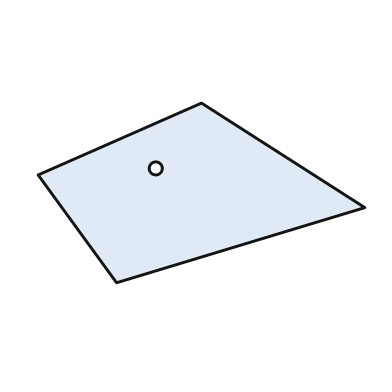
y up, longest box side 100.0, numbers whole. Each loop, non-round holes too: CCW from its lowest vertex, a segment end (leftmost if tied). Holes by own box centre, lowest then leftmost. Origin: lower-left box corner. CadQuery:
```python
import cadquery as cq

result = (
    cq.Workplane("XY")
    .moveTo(24.0, 0.0)
    .lineTo(100.0, 23.0)
    .lineTo(50.0, 55.0)
    .lineTo(0.0, 33.0)
    .close()
    .moveTo(36.0, 35.0)
    .circle(2.0)
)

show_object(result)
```